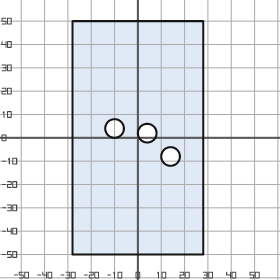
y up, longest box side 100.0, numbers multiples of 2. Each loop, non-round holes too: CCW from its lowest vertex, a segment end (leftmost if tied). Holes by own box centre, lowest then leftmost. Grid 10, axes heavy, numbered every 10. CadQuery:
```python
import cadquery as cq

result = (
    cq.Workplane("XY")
    .moveTo(-28.0, -50.0)
    .lineTo(28.0, -50.0)
    .lineTo(28.0, 50.0)
    .lineTo(-28.0, 50.0)
    .close()
    .moveTo(14.0, -8.0)
    .circle(4.0)
    .moveTo(4.0, 2.0)
    .circle(4.0)
    .moveTo(-10.0, 4.0)
    .circle(4.0)
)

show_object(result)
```